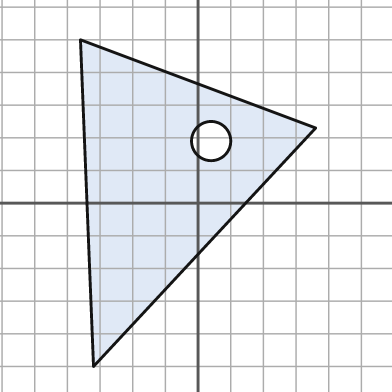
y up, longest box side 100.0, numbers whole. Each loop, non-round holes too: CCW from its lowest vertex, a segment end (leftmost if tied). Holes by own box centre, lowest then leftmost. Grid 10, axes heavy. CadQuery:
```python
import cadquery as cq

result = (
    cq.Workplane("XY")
    .moveTo(-32.0, -50.0)
    .lineTo(36.0, 23.0)
    .lineTo(-36.0, 50.0)
    .close()
    .moveTo(4.0, 19.0)
    .circle(6.0)
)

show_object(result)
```